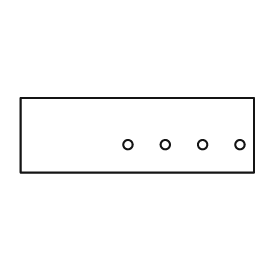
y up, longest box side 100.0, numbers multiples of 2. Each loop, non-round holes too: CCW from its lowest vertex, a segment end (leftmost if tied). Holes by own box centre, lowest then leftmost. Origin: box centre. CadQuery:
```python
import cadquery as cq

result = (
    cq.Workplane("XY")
    .moveTo(-50.0, -16.0)
    .lineTo(50.0, -16.0)
    .lineTo(50.0, 16.0)
    .lineTo(-50.0, 16.0)
    .close()
    .moveTo(-4.0, -4.0)
    .circle(2.0)
    .moveTo(12.0, -4.0)
    .circle(2.0)
    .moveTo(28.0, -4.0)
    .circle(2.0)
    .moveTo(44.0, -4.0)
    .circle(2.0)
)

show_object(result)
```